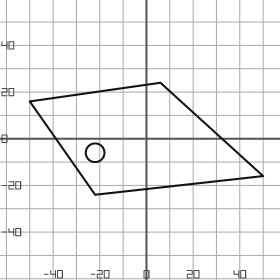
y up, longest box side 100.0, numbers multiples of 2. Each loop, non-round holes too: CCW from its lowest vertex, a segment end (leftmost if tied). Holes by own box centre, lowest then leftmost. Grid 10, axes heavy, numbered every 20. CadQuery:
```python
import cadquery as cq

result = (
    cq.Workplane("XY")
    .moveTo(-22.0, -24.0)
    .lineTo(50.0, -16.0)
    .lineTo(6.0, 24.0)
    .lineTo(-50.0, 16.0)
    .close()
    .moveTo(-22.0, -6.0)
    .circle(4.0)
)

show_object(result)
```